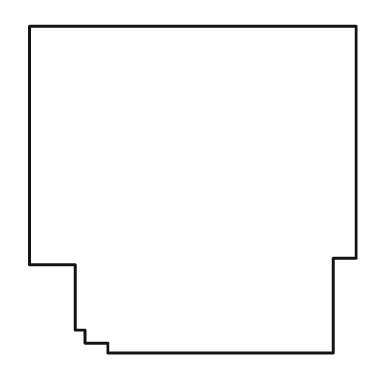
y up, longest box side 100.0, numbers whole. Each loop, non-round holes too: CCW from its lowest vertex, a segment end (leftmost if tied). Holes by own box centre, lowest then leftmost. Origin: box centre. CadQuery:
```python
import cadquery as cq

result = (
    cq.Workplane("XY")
    .moveTo(-26.0, -50.0)
    .lineTo(43.0, -50.0)
    .lineTo(43.0, -21.0)
    .lineTo(50.0, -21.0)
    .lineTo(50.0, 50.0)
    .lineTo(-50.0, 50.0)
    .lineTo(-50.0, -23.0)
    .lineTo(-36.0, -23.0)
    .lineTo(-36.0, -43.0)
    .lineTo(-33.0, -43.0)
    .lineTo(-33.0, -47.0)
    .lineTo(-26.0, -47.0)
    .close()
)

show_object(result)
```